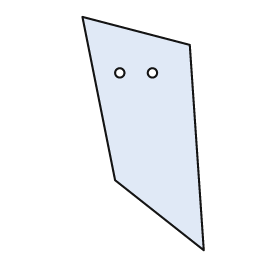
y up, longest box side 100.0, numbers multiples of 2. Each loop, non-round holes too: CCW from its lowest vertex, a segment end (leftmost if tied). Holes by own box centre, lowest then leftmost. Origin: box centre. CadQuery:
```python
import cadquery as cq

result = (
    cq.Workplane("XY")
    .moveTo(26.0, -50.0)
    .lineTo(20.0, 38.0)
    .lineTo(-26.0, 50.0)
    .lineTo(-12.0, -20.0)
    .close()
    .moveTo(-10.0, 26.0)
    .circle(2.0)
    .moveTo(4.0, 26.0)
    .circle(2.0)
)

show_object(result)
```